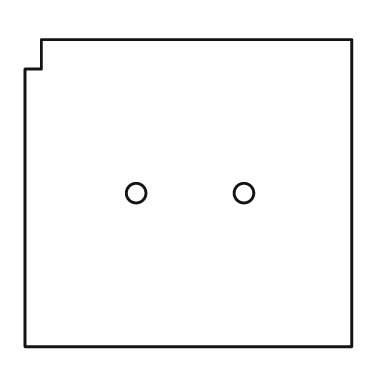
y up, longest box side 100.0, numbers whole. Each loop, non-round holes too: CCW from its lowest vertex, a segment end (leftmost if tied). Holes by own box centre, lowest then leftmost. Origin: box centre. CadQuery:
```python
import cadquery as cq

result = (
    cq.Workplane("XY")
    .moveTo(-50.0, -47.0)
    .lineTo(50.0, -47.0)
    .lineTo(50.0, 47.0)
    .lineTo(-45.0, 47.0)
    .lineTo(-45.0, 38.0)
    .lineTo(-50.0, 38.0)
    .close()
    .moveTo(-16.0, 0.0)
    .circle(3.0)
    .moveTo(17.0, 0.0)
    .circle(3.0)
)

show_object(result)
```